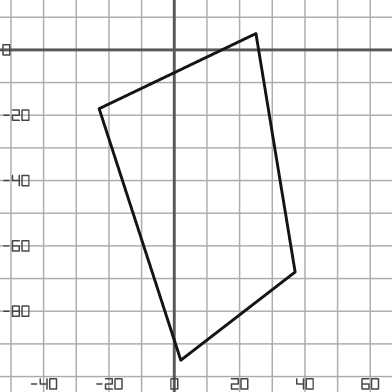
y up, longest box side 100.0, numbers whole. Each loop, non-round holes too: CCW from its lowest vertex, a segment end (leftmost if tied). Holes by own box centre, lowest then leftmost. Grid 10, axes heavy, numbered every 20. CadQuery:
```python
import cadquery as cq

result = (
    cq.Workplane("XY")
    .moveTo(2.0, -95.0)
    .lineTo(37.0, -68.0)
    .lineTo(25.0, 5.0)
    .lineTo(-23.0, -18.0)
    .close()
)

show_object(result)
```